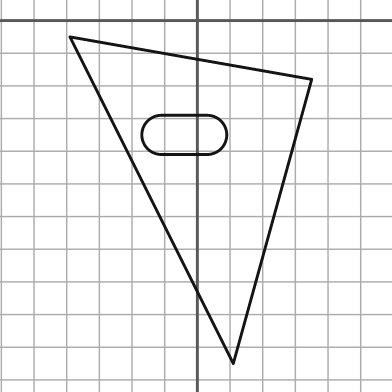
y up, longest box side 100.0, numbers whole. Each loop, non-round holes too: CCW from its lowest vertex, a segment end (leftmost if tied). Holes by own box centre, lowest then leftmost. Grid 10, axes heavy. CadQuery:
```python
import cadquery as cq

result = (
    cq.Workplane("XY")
    .moveTo(11.0, -105.0)
    .lineTo(35.0, -18.0)
    .lineTo(-39.0, -5.0)
    .close()
    .moveTo(-11.0, -41.0)
    .lineTo(3.0, -41.0)
    .threePointArc((9.0, -35.0), (3.0, -29.0))
    .lineTo(-11.0, -29.0)
    .threePointArc((-17.0, -35.0), (-11.0, -41.0))
    .close()
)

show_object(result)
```